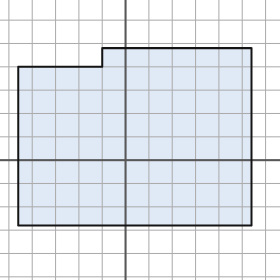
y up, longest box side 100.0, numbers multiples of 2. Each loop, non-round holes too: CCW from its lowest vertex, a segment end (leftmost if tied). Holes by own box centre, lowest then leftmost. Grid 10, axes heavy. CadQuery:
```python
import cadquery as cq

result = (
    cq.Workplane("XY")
    .moveTo(-46.0, -28.0)
    .lineTo(54.0, -28.0)
    .lineTo(54.0, 48.0)
    .lineTo(-10.0, 48.0)
    .lineTo(-10.0, 40.0)
    .lineTo(-46.0, 40.0)
    .close()
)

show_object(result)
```